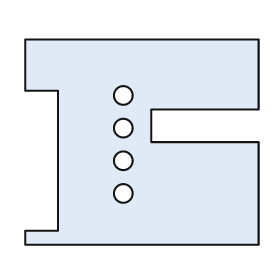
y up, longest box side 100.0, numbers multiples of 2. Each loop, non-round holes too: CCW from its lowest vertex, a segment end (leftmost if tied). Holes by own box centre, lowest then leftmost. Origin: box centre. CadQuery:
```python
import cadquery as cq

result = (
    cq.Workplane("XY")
    .moveTo(-50.0, -44.0)
    .lineTo(50.0, -44.0)
    .lineTo(50.0, 0.0)
    .lineTo(4.0, 0.0)
    .lineTo(4.0, 14.0)
    .lineTo(50.0, 14.0)
    .lineTo(50.0, 44.0)
    .lineTo(-50.0, 44.0)
    .lineTo(-50.0, 22.0)
    .lineTo(-36.0, 22.0)
    .lineTo(-36.0, -38.0)
    .lineTo(-50.0, -38.0)
    .close()
    .moveTo(-8.0, -22.0)
    .circle(4.0)
    .moveTo(-8.0, -8.0)
    .circle(4.0)
    .moveTo(-8.0, 6.0)
    .circle(4.0)
    .moveTo(-8.0, 20.0)
    .circle(4.0)
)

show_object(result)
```